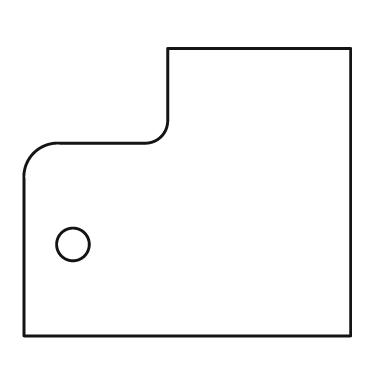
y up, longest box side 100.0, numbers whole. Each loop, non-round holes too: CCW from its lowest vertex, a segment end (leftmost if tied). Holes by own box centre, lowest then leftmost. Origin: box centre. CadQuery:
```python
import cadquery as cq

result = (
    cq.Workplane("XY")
    .moveTo(-50.0, -44.0)
    .lineTo(50.0, -44.0)
    .lineTo(50.0, 44.0)
    .lineTo(-6.0, 44.0)
    .lineTo(-6.0, 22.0)
    .threePointArc((-8.0, 17.0), (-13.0, 15.0))
    .lineTo(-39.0, 15.0)
    .threePointArc((-47.0, 12.0), (-50.0, 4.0))
    .close()
    .moveTo(-35.0, -16.0)
    .circle(5.0)
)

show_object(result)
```